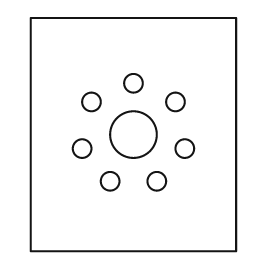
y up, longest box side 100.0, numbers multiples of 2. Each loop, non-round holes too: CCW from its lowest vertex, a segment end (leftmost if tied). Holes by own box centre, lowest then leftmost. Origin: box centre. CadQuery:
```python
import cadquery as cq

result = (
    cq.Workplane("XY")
    .moveTo(-44.0, -50.0)
    .lineTo(44.0, -50.0)
    .lineTo(44.0, 50.0)
    .lineTo(-44.0, 50.0)
    .close()
    .moveTo(-10.0, -20.0)
    .circle(4.0)
    .moveTo(10.0, -20.0)
    .circle(4.0)
    .moveTo(-22.0, -6.0)
    .circle(4.0)
    .moveTo(22.0, -6.0)
    .circle(4.0)
    .moveTo(0.0, 0.0)
    .circle(10.0)
    .moveTo(-18.0, 14.0)
    .circle(4.0)
    .moveTo(18.0, 14.0)
    .circle(4.0)
    .moveTo(0.0, 22.0)
    .circle(4.0)
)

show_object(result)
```